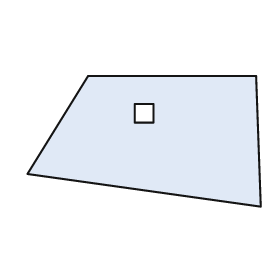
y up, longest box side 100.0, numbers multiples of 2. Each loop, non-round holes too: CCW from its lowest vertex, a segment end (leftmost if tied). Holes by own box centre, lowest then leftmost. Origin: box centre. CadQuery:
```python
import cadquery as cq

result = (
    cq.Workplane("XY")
    .moveTo(50.0, -28.0)
    .lineTo(48.0, 28.0)
    .lineTo(-24.0, 28.0)
    .lineTo(-50.0, -14.0)
    .close()
    .moveTo(-4.0, 8.0)
    .lineTo(4.0, 8.0)
    .lineTo(4.0, 16.0)
    .lineTo(-4.0, 16.0)
    .close()
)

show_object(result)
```